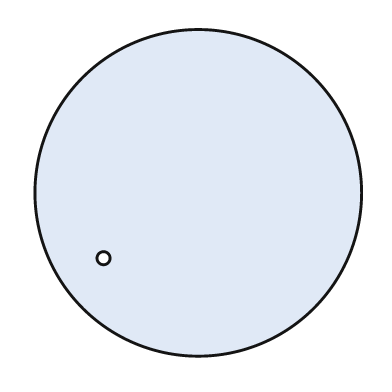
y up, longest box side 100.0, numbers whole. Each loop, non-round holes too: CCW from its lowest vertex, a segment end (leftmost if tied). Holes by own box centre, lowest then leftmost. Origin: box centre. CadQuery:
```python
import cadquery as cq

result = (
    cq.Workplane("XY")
    .moveTo(0.0, 0.0)
    .circle(50.0)
    .moveTo(-29.0, -20.0)
    .circle(2.0)
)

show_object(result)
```